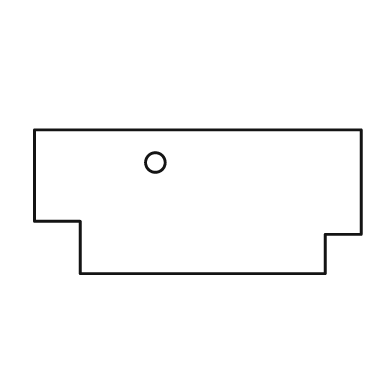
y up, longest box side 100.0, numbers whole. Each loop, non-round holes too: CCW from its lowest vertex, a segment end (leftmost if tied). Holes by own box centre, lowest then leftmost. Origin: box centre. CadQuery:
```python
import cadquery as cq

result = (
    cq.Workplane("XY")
    .moveTo(-36.0, -22.0)
    .lineTo(39.0, -22.0)
    .lineTo(39.0, -10.0)
    .lineTo(50.0, -10.0)
    .lineTo(50.0, 22.0)
    .lineTo(-50.0, 22.0)
    .lineTo(-50.0, -6.0)
    .lineTo(-36.0, -6.0)
    .close()
    .moveTo(-13.0, 12.0)
    .circle(3.0)
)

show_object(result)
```